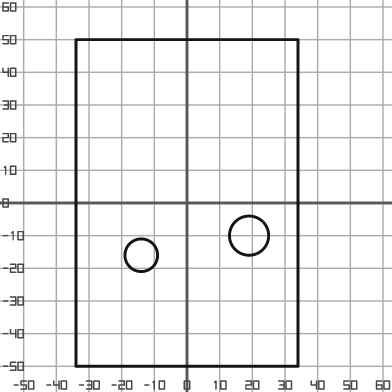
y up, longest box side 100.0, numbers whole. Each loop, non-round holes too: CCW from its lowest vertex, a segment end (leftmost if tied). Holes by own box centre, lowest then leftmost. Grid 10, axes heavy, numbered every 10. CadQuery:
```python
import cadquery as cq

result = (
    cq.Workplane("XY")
    .moveTo(-34.0, -50.0)
    .lineTo(34.0, -50.0)
    .lineTo(34.0, 50.0)
    .lineTo(-34.0, 50.0)
    .close()
    .moveTo(-14.0, -16.0)
    .circle(5.0)
    .moveTo(19.0, -10.0)
    .circle(6.0)
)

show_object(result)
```